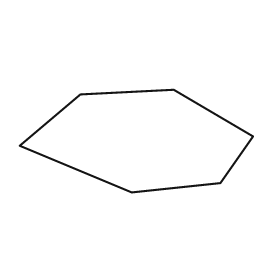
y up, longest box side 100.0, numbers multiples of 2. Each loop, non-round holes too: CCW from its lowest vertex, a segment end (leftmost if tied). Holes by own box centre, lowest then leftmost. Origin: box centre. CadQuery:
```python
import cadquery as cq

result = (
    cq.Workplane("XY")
    .moveTo(-2.0, -22.0)
    .lineTo(36.0, -18.0)
    .lineTo(50.0, 2.0)
    .lineTo(16.0, 22.0)
    .lineTo(-24.0, 20.0)
    .lineTo(-50.0, -2.0)
    .close()
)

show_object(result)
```